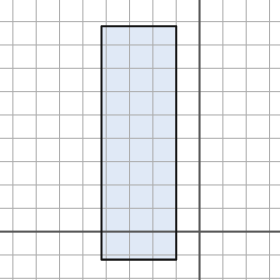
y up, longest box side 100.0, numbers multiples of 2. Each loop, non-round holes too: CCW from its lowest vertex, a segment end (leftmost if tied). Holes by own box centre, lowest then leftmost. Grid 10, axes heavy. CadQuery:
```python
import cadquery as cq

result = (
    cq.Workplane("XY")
    .moveTo(-42.0, -12.0)
    .lineTo(-10.0, -12.0)
    .lineTo(-10.0, 88.0)
    .lineTo(-42.0, 88.0)
    .close()
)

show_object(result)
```